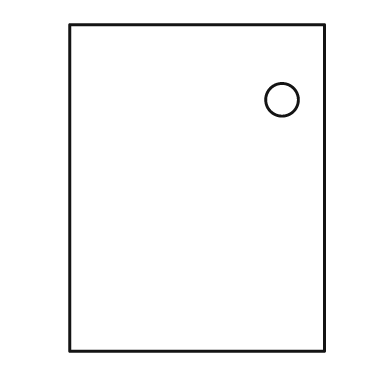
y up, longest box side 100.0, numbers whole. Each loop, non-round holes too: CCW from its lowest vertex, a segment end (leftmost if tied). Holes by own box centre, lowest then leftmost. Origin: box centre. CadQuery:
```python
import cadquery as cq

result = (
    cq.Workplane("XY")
    .moveTo(-39.0, -50.0)
    .lineTo(39.0, -50.0)
    .lineTo(39.0, 50.0)
    .lineTo(-39.0, 50.0)
    .close()
    .moveTo(26.0, 27.0)
    .circle(5.0)
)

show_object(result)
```